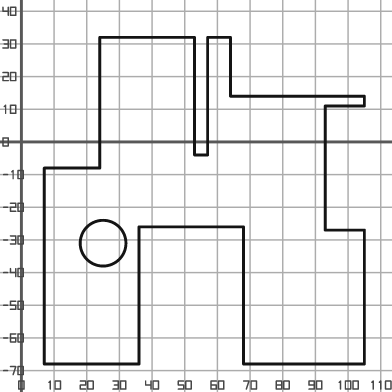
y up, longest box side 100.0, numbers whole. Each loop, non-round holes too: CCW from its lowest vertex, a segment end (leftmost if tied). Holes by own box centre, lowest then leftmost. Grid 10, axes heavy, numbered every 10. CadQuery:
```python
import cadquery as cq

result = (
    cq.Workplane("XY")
    .moveTo(7.0, -68.0)
    .lineTo(36.0, -68.0)
    .lineTo(36.0, -26.0)
    .lineTo(68.0, -26.0)
    .lineTo(68.0, -68.0)
    .lineTo(105.0, -68.0)
    .lineTo(105.0, -27.0)
    .lineTo(93.0, -27.0)
    .lineTo(93.0, 11.0)
    .lineTo(105.0, 11.0)
    .lineTo(105.0, 14.0)
    .lineTo(64.0, 14.0)
    .lineTo(64.0, 32.0)
    .lineTo(57.0, 32.0)
    .lineTo(57.0, -4.0)
    .lineTo(53.0, -4.0)
    .lineTo(53.0, 32.0)
    .lineTo(24.0, 32.0)
    .lineTo(24.0, -8.0)
    .lineTo(7.0, -8.0)
    .close()
    .moveTo(25.0, -31.0)
    .circle(7.0)
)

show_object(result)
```